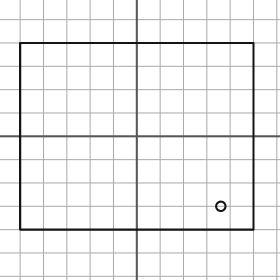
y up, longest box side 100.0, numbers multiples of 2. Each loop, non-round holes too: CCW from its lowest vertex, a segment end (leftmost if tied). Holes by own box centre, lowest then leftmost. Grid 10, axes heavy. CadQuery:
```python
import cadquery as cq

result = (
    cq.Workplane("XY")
    .moveTo(-50.0, -40.0)
    .lineTo(50.0, -40.0)
    .lineTo(50.0, 40.0)
    .lineTo(-50.0, 40.0)
    .close()
    .moveTo(36.0, -30.0)
    .circle(2.0)
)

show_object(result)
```